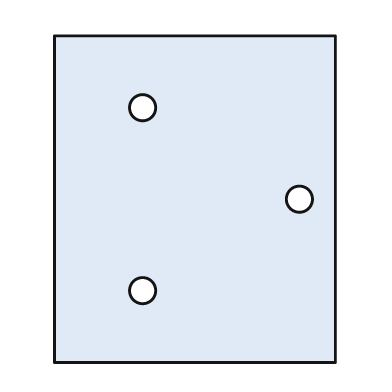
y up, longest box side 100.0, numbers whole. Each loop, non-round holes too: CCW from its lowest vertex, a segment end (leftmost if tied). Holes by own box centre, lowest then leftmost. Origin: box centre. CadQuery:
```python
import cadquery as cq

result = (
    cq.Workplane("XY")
    .moveTo(-43.0, -50.0)
    .lineTo(43.0, -50.0)
    .lineTo(43.0, 50.0)
    .lineTo(-43.0, 50.0)
    .close()
    .moveTo(-16.0, -28.0)
    .circle(4.0)
    .moveTo(32.0, 0.0)
    .circle(4.0)
    .moveTo(-16.0, 28.0)
    .circle(4.0)
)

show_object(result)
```